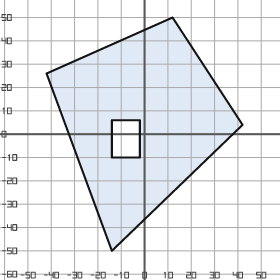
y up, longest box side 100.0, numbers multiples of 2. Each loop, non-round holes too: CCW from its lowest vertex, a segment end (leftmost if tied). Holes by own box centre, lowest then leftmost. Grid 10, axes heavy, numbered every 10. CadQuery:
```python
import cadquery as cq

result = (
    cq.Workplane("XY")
    .moveTo(-14.0, -50.0)
    .lineTo(42.0, 4.0)
    .lineTo(12.0, 50.0)
    .lineTo(-42.0, 26.0)
    .close()
    .moveTo(-14.0, -10.0)
    .lineTo(-2.0, -10.0)
    .lineTo(-2.0, 6.0)
    .lineTo(-14.0, 6.0)
    .close()
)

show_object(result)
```